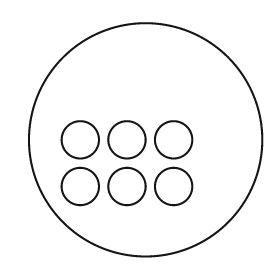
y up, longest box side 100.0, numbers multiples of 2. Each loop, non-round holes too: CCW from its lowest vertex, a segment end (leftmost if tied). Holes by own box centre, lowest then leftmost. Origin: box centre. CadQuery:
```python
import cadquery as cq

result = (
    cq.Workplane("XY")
    .moveTo(0.0, 0.0)
    .circle(50.0)
    .moveTo(-28.0, -20.0)
    .circle(8.0)
    .moveTo(-8.0, -20.0)
    .circle(8.0)
    .moveTo(12.0, -20.0)
    .circle(8.0)
    .moveTo(-28.0, 0.0)
    .circle(8.0)
    .moveTo(-8.0, 0.0)
    .circle(8.0)
    .moveTo(12.0, 0.0)
    .circle(8.0)
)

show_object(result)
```